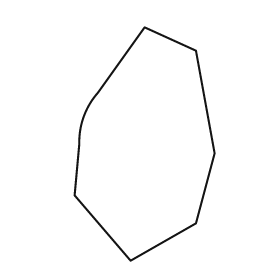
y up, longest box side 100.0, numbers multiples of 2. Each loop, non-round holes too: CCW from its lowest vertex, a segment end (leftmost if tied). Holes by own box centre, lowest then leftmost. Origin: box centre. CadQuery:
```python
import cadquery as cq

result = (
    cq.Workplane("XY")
    .moveTo(-6.0, -50.0)
    .lineTo(22.0, -34.0)
    .lineTo(30.0, -4.0)
    .lineTo(22.0, 40.0)
    .lineTo(0.0, 50.0)
    .lineTo(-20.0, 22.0)
    .threePointArc((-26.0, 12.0), (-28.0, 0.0))
    .lineTo(-30.0, -22.0)
    .close()
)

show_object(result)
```